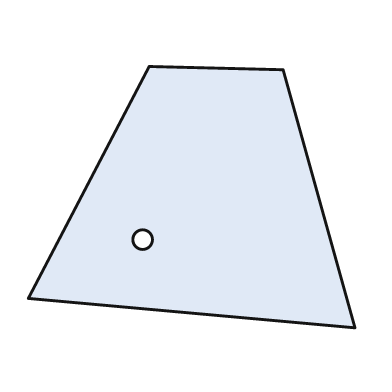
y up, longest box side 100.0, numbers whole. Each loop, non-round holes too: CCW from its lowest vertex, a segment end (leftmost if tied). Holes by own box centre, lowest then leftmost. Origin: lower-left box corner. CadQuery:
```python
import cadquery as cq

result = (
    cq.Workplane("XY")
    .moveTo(100.0, 0.0)
    .lineTo(78.0, 79.0)
    .lineTo(37.0, 80.0)
    .lineTo(0.0, 9.0)
    .close()
    .moveTo(35.0, 27.0)
    .circle(3.0)
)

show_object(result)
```